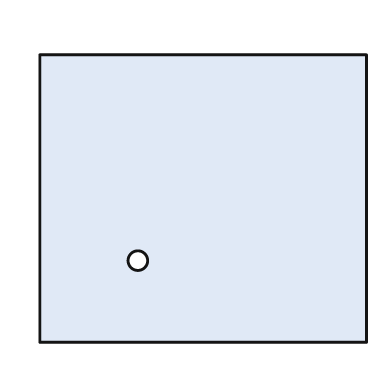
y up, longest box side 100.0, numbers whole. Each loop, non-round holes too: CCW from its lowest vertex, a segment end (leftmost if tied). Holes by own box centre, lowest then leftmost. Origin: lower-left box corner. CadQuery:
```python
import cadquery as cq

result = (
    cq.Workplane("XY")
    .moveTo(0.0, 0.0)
    .lineTo(100.0, 0.0)
    .lineTo(100.0, 88.0)
    .lineTo(0.0, 88.0)
    .close()
    .moveTo(30.0, 25.0)
    .circle(3.0)
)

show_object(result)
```